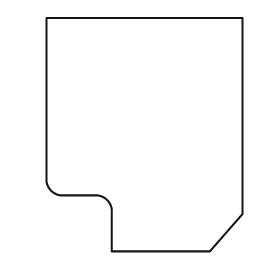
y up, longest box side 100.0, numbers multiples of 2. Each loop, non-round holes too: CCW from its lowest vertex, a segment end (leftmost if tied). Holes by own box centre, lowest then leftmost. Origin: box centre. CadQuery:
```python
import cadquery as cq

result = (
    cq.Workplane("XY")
    .moveTo(-14.0, -50.0)
    .lineTo(28.0, -50.0)
    .lineTo(42.0, -34.0)
    .lineTo(42.0, 50.0)
    .lineTo(-42.0, 50.0)
    .lineTo(-42.0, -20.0)
    .threePointArc((-40.0, -24.0), (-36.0, -26.0))
    .lineTo(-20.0, -26.0)
    .threePointArc((-16.0, -28.0), (-14.0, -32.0))
    .close()
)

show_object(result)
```